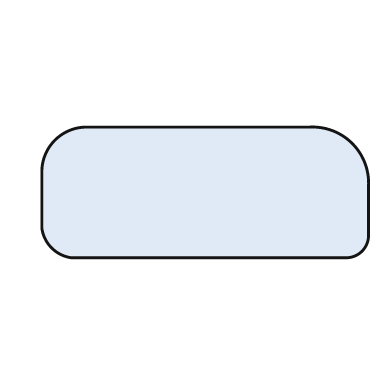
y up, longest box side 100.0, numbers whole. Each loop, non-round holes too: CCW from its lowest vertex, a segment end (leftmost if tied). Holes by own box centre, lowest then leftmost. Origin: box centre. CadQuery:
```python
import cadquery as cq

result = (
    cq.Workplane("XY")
    .moveTo(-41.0, -20.0)
    .lineTo(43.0, -20.0)
    .threePointArc((48.0, -18.0), (50.0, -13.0))
    .lineTo(50.0, 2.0)
    .threePointArc((45.0, 15.0), (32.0, 20.0))
    .lineTo(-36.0, 20.0)
    .threePointArc((-46.0, 16.0), (-50.0, 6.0))
    .lineTo(-50.0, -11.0)
    .threePointArc((-47.0, -17.0), (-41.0, -20.0))
    .close()
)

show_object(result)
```